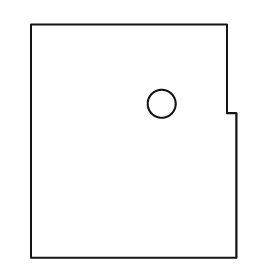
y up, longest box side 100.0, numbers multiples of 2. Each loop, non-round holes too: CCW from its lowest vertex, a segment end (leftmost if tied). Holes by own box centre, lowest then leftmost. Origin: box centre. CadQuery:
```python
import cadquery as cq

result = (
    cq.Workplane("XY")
    .moveTo(-44.0, -50.0)
    .lineTo(44.0, -50.0)
    .lineTo(44.0, 12.0)
    .lineTo(40.0, 12.0)
    .lineTo(40.0, 50.0)
    .lineTo(-44.0, 50.0)
    .close()
    .moveTo(12.0, 16.0)
    .circle(6.0)
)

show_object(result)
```